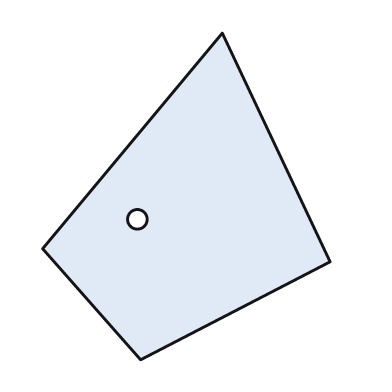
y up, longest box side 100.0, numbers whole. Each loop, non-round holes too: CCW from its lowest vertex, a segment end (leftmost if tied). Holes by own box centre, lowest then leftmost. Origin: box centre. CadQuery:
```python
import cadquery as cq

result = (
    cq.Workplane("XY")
    .moveTo(-14.0, -50.0)
    .lineTo(44.0, -20.0)
    .lineTo(11.0, 50.0)
    .lineTo(-44.0, -16.0)
    .close()
    .moveTo(-15.0, -7.0)
    .circle(3.0)
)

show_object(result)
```